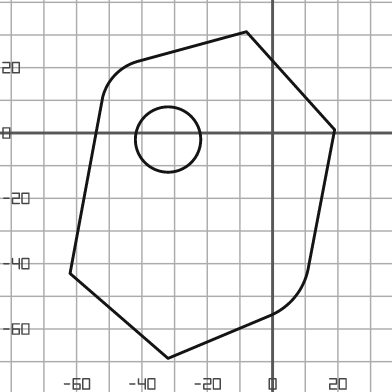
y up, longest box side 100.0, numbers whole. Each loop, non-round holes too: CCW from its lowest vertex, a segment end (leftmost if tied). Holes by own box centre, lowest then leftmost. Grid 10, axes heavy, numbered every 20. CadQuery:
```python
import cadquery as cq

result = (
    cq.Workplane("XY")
    .moveTo(-32.0, -69.0)
    .lineTo(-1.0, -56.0)
    .threePointArc((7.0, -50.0), (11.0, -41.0))
    .lineTo(19.0, 1.0)
    .lineTo(-8.0, 31.0)
    .lineTo(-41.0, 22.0)
    .threePointArc((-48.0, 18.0), (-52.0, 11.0))
    .lineTo(-62.0, -43.0)
    .close()
    .moveTo(-32.0, -2.0)
    .circle(10.0)
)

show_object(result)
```